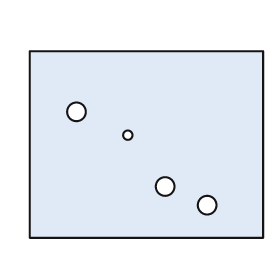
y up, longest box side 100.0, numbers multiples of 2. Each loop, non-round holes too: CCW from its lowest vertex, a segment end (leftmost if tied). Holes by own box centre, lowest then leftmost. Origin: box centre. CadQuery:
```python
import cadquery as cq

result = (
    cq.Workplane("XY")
    .moveTo(-50.0, -40.0)
    .lineTo(50.0, -40.0)
    .lineTo(50.0, 40.0)
    .lineTo(-50.0, 40.0)
    .close()
    .moveTo(26.0, -26.0)
    .circle(4.0)
    .moveTo(8.0, -18.0)
    .circle(4.0)
    .moveTo(-8.0, 4.0)
    .circle(2.0)
    .moveTo(-30.0, 14.0)
    .circle(4.0)
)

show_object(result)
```